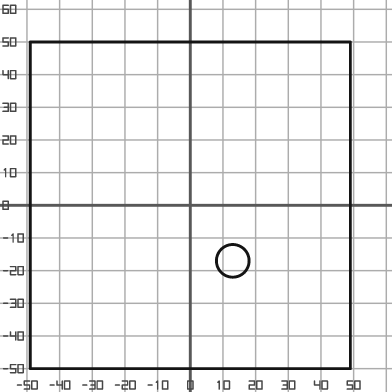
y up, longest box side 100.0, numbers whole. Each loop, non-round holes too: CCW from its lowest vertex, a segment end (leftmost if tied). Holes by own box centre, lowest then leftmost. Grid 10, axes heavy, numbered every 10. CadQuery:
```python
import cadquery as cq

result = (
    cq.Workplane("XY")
    .moveTo(-49.0, -50.0)
    .lineTo(49.0, -50.0)
    .lineTo(49.0, 50.0)
    .lineTo(-49.0, 50.0)
    .close()
    .moveTo(13.0, -17.0)
    .circle(5.0)
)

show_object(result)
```